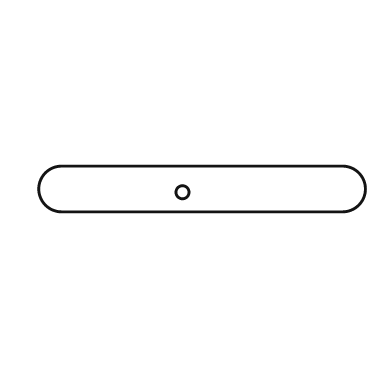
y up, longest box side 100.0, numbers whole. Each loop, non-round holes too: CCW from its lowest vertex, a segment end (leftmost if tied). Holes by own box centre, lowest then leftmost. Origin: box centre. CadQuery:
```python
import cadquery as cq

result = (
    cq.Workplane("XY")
    .moveTo(-43.0, -7.0)
    .lineTo(43.0, -7.0)
    .threePointArc((50.0, 0.0), (43.0, 7.0))
    .lineTo(-43.0, 7.0)
    .threePointArc((-50.0, 0.0), (-43.0, -7.0))
    .close()
    .moveTo(-6.0, -1.0)
    .circle(2.0)
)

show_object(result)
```